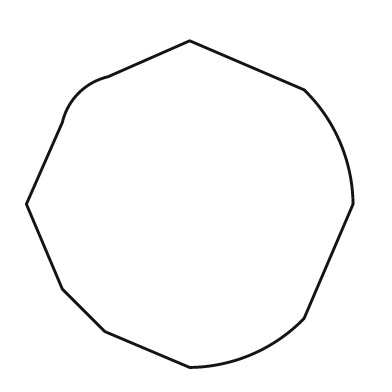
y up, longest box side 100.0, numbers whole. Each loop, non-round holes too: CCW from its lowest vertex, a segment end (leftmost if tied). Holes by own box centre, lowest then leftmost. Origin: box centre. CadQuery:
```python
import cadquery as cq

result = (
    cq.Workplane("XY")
    .moveTo(0.0, -50.0)
    .threePointArc((19.0, -46.0), (35.0, -35.0))
    .lineTo(50.0, 0.0)
    .threePointArc((46.0, 19.0), (35.0, 35.0))
    .lineTo(0.0, 50.0)
    .lineTo(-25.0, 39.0)
    .threePointArc((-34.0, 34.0), (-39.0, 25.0))
    .lineTo(-50.0, 0.0)
    .lineTo(-39.0, -26.0)
    .lineTo(-26.0, -39.0)
    .close()
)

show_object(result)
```